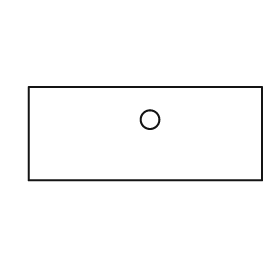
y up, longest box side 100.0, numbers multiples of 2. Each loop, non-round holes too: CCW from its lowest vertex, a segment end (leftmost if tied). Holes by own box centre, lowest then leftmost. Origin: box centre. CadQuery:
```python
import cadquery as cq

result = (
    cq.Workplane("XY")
    .moveTo(-50.0, -20.0)
    .lineTo(50.0, -20.0)
    .lineTo(50.0, 20.0)
    .lineTo(-50.0, 20.0)
    .close()
    .moveTo(2.0, 6.0)
    .circle(4.0)
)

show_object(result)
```